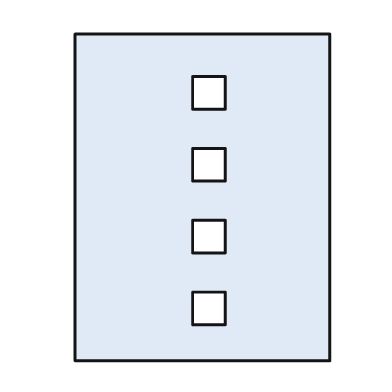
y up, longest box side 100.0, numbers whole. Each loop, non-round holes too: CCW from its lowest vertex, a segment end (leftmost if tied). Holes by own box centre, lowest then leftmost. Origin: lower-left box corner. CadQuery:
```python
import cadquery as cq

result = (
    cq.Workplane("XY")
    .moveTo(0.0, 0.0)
    .lineTo(78.0, 0.0)
    .lineTo(78.0, 100.0)
    .lineTo(0.0, 100.0)
    .close()
    .moveTo(36.0, 11.0)
    .lineTo(46.0, 11.0)
    .lineTo(46.0, 21.0)
    .lineTo(36.0, 21.0)
    .close()
    .moveTo(36.0, 33.0)
    .lineTo(46.0, 33.0)
    .lineTo(46.0, 43.0)
    .lineTo(36.0, 43.0)
    .close()
    .moveTo(36.0, 55.0)
    .lineTo(46.0, 55.0)
    .lineTo(46.0, 65.0)
    .lineTo(36.0, 65.0)
    .close()
    .moveTo(36.0, 77.0)
    .lineTo(46.0, 77.0)
    .lineTo(46.0, 87.0)
    .lineTo(36.0, 87.0)
    .close()
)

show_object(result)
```